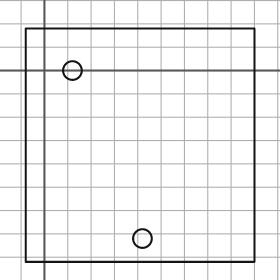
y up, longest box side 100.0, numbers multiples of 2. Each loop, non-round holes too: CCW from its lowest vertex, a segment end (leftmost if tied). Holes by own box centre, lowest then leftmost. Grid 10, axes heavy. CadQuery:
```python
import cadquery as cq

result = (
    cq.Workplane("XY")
    .moveTo(-8.0, -82.0)
    .lineTo(90.0, -82.0)
    .lineTo(90.0, 18.0)
    .lineTo(-8.0, 18.0)
    .close()
    .moveTo(42.0, -72.0)
    .circle(4.0)
    .moveTo(12.0, 0.0)
    .circle(4.0)
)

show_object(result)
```